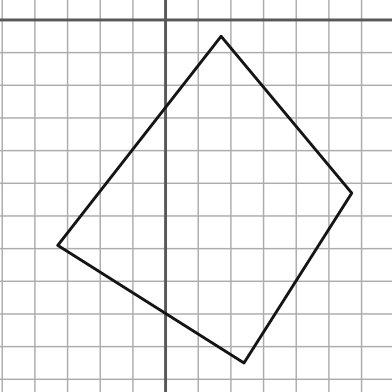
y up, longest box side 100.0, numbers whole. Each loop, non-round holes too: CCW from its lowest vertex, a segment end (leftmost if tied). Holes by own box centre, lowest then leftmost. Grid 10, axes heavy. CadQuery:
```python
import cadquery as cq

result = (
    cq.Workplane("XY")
    .moveTo(24.0, -105.0)
    .lineTo(57.0, -53.0)
    .lineTo(17.0, -5.0)
    .lineTo(-33.0, -69.0)
    .close()
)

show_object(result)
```